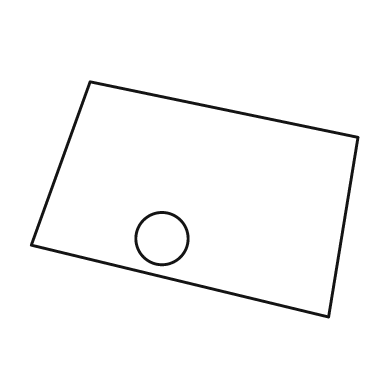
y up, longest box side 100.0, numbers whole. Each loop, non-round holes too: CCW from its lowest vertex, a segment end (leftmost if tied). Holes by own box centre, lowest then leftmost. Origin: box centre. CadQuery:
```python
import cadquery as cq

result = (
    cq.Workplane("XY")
    .moveTo(41.0, -36.0)
    .lineTo(50.0, 19.0)
    .lineTo(-32.0, 36.0)
    .lineTo(-50.0, -14.0)
    .close()
    .moveTo(-10.0, -12.0)
    .circle(8.0)
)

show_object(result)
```